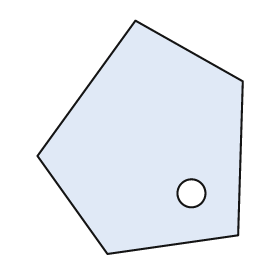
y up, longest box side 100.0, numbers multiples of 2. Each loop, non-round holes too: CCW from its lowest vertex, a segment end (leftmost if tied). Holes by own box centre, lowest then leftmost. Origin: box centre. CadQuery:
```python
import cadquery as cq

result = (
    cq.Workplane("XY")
    .moveTo(-14.0, -50.0)
    .lineTo(42.0, -42.0)
    .lineTo(44.0, 24.0)
    .lineTo(-2.0, 50.0)
    .lineTo(-44.0, -8.0)
    .close()
    .moveTo(22.0, -24.0)
    .circle(6.0)
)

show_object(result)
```